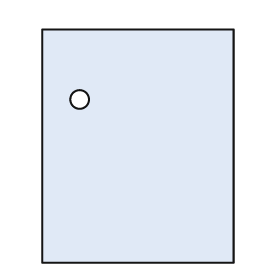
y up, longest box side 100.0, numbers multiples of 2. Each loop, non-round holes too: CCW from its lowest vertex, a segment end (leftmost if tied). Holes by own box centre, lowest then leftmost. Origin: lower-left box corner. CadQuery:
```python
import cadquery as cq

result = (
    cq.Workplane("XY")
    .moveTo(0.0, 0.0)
    .lineTo(82.0, 0.0)
    .lineTo(82.0, 100.0)
    .lineTo(0.0, 100.0)
    .close()
    .moveTo(16.0, 70.0)
    .circle(4.0)
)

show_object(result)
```